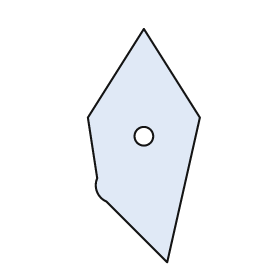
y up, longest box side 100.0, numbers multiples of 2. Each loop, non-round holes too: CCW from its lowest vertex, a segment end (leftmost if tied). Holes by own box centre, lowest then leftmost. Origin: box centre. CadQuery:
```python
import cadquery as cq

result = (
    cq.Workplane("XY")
    .moveTo(10.0, -50.0)
    .lineTo(24.0, 12.0)
    .lineTo(0.0, 50.0)
    .lineTo(-24.0, 12.0)
    .lineTo(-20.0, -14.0)
    .threePointArc((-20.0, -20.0), (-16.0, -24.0))
    .close()
    .moveTo(0.0, 4.0)
    .circle(4.0)
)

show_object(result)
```